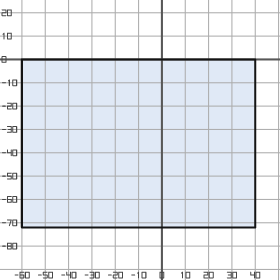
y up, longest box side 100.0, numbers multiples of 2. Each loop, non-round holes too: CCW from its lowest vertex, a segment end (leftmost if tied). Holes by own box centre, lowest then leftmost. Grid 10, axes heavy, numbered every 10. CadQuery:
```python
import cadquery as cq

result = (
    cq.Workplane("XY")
    .moveTo(-60.0, -72.0)
    .lineTo(40.0, -72.0)
    .lineTo(40.0, 0.0)
    .lineTo(-60.0, 0.0)
    .close()
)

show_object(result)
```